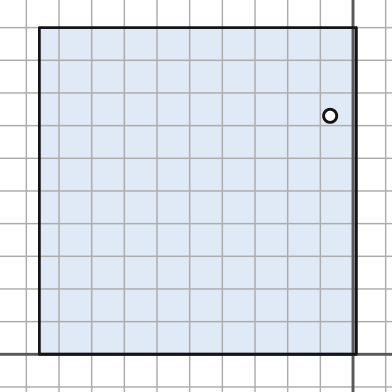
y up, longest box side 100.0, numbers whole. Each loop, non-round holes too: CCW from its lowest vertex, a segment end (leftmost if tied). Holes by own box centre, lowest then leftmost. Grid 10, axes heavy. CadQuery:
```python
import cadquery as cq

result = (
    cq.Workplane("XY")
    .moveTo(-96.0, 0.0)
    .lineTo(1.0, 0.0)
    .lineTo(1.0, 100.0)
    .lineTo(-96.0, 100.0)
    .close()
    .moveTo(-7.0, 73.0)
    .circle(2.0)
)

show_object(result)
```